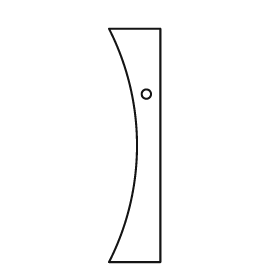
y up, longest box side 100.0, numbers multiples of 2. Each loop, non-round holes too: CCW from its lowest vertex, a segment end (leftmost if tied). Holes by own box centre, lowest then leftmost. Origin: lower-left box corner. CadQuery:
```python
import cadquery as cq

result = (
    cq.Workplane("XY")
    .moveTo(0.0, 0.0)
    .lineTo(22.0, 0.0)
    .lineTo(22.0, 100.0)
    .lineTo(0.0, 100.0)
    .threePointArc((12.0, 50.0), (0.0, 0.0))
    .close()
    .moveTo(16.0, 72.0)
    .circle(2.0)
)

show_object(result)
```